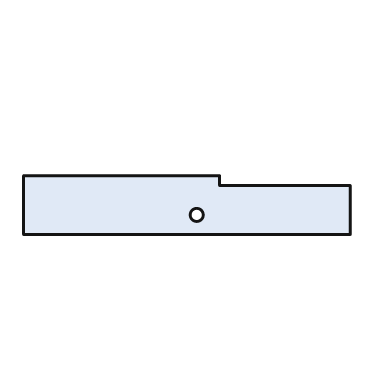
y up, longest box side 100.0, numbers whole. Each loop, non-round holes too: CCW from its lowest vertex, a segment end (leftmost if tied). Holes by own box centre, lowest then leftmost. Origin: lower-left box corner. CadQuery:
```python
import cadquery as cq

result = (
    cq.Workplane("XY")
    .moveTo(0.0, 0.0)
    .lineTo(100.0, 0.0)
    .lineTo(100.0, 15.0)
    .lineTo(60.0, 15.0)
    .lineTo(60.0, 18.0)
    .lineTo(0.0, 18.0)
    .close()
    .moveTo(53.0, 6.0)
    .circle(2.0)
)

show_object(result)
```